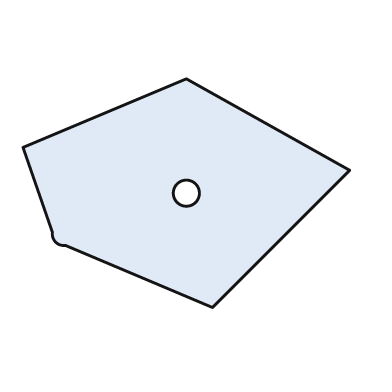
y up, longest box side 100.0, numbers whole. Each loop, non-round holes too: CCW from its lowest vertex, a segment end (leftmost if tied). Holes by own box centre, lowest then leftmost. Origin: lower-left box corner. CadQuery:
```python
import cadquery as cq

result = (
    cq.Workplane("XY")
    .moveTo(58.0, 0.0)
    .lineTo(100.0, 42.0)
    .lineTo(50.0, 70.0)
    .lineTo(0.0, 49.0)
    .lineTo(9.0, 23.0)
    .threePointArc((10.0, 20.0), (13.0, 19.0))
    .close()
    .moveTo(50.0, 35.0)
    .circle(4.0)
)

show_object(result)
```